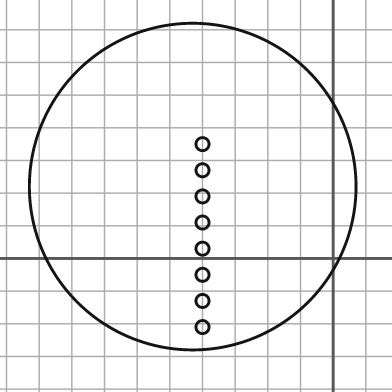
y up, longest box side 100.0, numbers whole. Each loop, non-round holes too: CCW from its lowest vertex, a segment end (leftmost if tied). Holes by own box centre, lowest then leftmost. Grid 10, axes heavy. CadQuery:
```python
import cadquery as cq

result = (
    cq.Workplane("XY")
    .moveTo(-43.0, 22.0)
    .circle(50.0)
    .moveTo(-40.0, -21.0)
    .circle(2.0)
    .moveTo(-40.0, -13.0)
    .circle(2.0)
    .moveTo(-40.0, -5.0)
    .circle(2.0)
    .moveTo(-40.0, 3.0)
    .circle(2.0)
    .moveTo(-40.0, 11.0)
    .circle(2.0)
    .moveTo(-40.0, 19.0)
    .circle(2.0)
    .moveTo(-40.0, 27.0)
    .circle(2.0)
    .moveTo(-40.0, 35.0)
    .circle(2.0)
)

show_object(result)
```